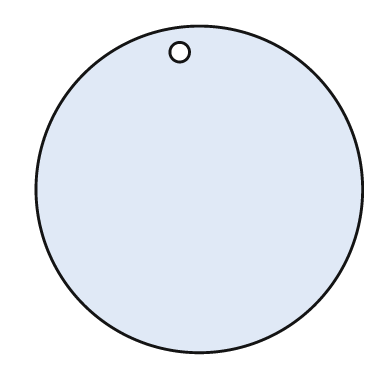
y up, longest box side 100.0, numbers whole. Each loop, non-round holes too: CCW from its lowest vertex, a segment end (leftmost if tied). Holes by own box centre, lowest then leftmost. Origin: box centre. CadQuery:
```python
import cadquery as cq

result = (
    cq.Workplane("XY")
    .moveTo(0.0, 0.0)
    .circle(50.0)
    .moveTo(-6.0, 42.0)
    .circle(3.0)
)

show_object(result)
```